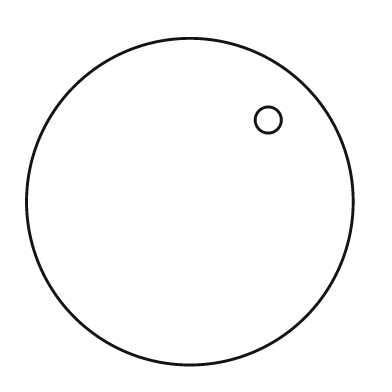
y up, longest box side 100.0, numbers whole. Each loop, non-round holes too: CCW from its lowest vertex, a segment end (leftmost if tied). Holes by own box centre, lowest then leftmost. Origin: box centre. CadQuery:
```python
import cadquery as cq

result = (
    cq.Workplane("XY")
    .moveTo(0.0, 0.0)
    .circle(50.0)
    .moveTo(24.0, 25.0)
    .circle(4.0)
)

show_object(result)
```